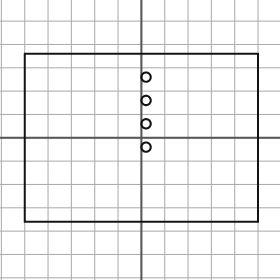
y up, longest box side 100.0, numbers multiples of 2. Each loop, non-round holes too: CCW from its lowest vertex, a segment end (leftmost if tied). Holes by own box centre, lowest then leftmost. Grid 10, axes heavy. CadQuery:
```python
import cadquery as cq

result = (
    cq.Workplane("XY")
    .moveTo(-50.0, -36.0)
    .lineTo(50.0, -36.0)
    .lineTo(50.0, 36.0)
    .lineTo(-50.0, 36.0)
    .close()
    .moveTo(2.0, -4.0)
    .circle(2.0)
    .moveTo(2.0, 6.0)
    .circle(2.0)
    .moveTo(2.0, 16.0)
    .circle(2.0)
    .moveTo(2.0, 26.0)
    .circle(2.0)
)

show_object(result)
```